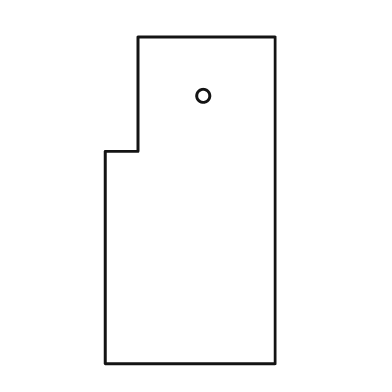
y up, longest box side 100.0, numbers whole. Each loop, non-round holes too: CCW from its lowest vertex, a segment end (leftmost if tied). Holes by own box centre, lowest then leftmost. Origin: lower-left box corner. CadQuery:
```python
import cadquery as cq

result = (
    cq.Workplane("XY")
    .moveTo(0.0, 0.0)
    .lineTo(52.0, 0.0)
    .lineTo(52.0, 100.0)
    .lineTo(10.0, 100.0)
    .lineTo(10.0, 65.0)
    .lineTo(0.0, 65.0)
    .close()
    .moveTo(30.0, 82.0)
    .circle(2.0)
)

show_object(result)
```